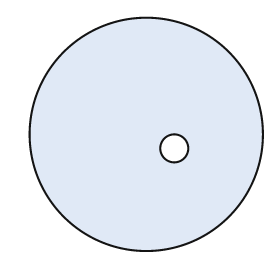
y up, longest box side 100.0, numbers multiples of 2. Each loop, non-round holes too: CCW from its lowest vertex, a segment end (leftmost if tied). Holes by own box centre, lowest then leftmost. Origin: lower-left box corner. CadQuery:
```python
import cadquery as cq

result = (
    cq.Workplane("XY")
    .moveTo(50.0, 50.0)
    .circle(50.0)
    .moveTo(62.0, 44.0)
    .circle(6.0)
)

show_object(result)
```